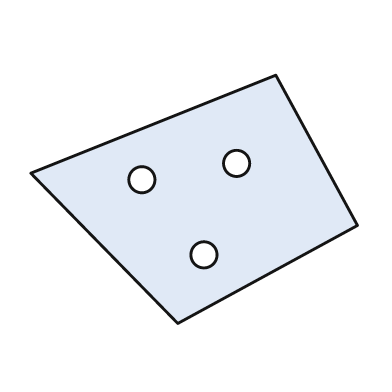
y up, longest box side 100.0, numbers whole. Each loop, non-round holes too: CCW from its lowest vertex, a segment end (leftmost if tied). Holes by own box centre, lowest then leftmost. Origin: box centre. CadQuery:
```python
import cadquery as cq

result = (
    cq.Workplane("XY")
    .moveTo(-5.0, -38.0)
    .lineTo(50.0, -8.0)
    .lineTo(25.0, 38.0)
    .lineTo(-50.0, 8.0)
    .close()
    .moveTo(3.0, -17.0)
    .circle(4.0)
    .moveTo(-16.0, 6.0)
    .circle(4.0)
    .moveTo(13.0, 11.0)
    .circle(4.0)
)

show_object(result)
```